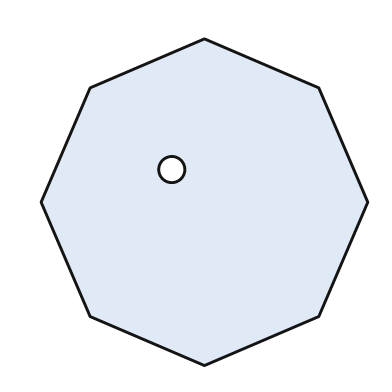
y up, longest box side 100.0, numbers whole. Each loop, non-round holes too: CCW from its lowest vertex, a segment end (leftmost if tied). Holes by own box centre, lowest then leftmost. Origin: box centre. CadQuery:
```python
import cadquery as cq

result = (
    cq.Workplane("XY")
    .moveTo(0.0, -50.0)
    .lineTo(35.0, -35.0)
    .lineTo(50.0, 0.0)
    .lineTo(35.0, 35.0)
    .lineTo(0.0, 50.0)
    .lineTo(-35.0, 35.0)
    .lineTo(-50.0, 0.0)
    .lineTo(-35.0, -35.0)
    .close()
    .moveTo(-10.0, 10.0)
    .circle(4.0)
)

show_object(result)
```